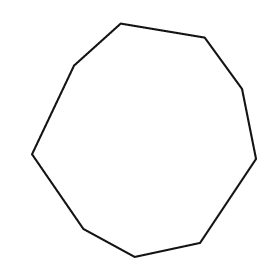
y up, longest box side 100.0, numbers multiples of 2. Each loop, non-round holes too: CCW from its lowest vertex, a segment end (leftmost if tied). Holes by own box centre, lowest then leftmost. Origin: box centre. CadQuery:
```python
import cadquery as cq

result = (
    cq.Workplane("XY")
    .moveTo(-4.0, -50.0)
    .lineTo(24.0, -44.0)
    .lineTo(48.0, -8.0)
    .lineTo(42.0, 22.0)
    .lineTo(26.0, 44.0)
    .lineTo(-10.0, 50.0)
    .lineTo(-30.0, 32.0)
    .lineTo(-48.0, -6.0)
    .lineTo(-26.0, -38.0)
    .close()
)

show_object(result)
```